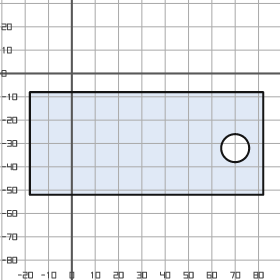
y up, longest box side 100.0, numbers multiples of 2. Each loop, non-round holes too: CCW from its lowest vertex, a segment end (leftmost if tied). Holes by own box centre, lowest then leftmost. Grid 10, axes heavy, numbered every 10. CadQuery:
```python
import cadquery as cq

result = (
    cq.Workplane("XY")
    .moveTo(-18.0, -52.0)
    .lineTo(82.0, -52.0)
    .lineTo(82.0, -8.0)
    .lineTo(-18.0, -8.0)
    .close()
    .moveTo(70.0, -32.0)
    .circle(6.0)
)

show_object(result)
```